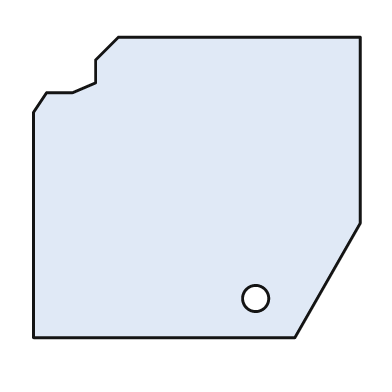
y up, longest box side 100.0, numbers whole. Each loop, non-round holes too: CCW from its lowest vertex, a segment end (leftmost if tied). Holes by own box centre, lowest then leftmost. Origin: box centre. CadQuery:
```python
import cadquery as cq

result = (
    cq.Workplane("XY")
    .moveTo(-50.0, -46.0)
    .lineTo(30.0, -46.0)
    .lineTo(50.0, -11.0)
    .lineTo(50.0, 46.0)
    .lineTo(-24.0, 46.0)
    .lineTo(-31.0, 39.0)
    .lineTo(-31.0, 32.0)
    .lineTo(-38.0, 29.0)
    .lineTo(-46.0, 29.0)
    .lineTo(-50.0, 23.0)
    .close()
    .moveTo(18.0, -34.0)
    .circle(4.0)
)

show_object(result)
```